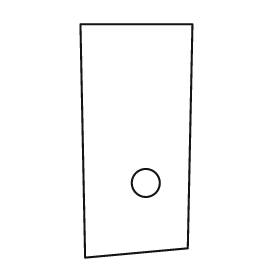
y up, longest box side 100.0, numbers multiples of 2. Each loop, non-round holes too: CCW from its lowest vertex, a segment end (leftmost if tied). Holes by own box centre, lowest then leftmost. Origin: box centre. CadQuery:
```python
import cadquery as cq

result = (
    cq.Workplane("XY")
    .moveTo(-22.0, -50.0)
    .lineTo(22.0, -46.0)
    .lineTo(24.0, 50.0)
    .lineTo(-24.0, 50.0)
    .close()
    .moveTo(4.0, -18.0)
    .circle(6.0)
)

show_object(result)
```